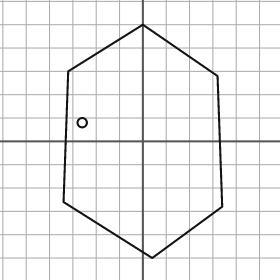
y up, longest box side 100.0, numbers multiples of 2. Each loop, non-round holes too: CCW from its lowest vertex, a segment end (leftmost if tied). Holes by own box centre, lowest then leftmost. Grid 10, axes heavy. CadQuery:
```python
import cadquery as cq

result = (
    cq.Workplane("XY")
    .moveTo(4.0, -50.0)
    .lineTo(34.0, -28.0)
    .lineTo(32.0, 28.0)
    .lineTo(0.0, 50.0)
    .lineTo(-32.0, 30.0)
    .lineTo(-34.0, -26.0)
    .close()
    .moveTo(-26.0, 8.0)
    .circle(2.0)
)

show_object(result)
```